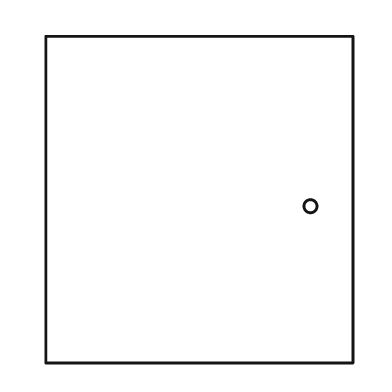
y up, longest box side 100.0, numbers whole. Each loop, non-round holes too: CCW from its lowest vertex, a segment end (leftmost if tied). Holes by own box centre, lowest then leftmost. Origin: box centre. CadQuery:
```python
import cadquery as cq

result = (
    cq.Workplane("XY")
    .moveTo(-47.0, -50.0)
    .lineTo(47.0, -50.0)
    .lineTo(47.0, 50.0)
    .lineTo(-47.0, 50.0)
    .close()
    .moveTo(34.0, -2.0)
    .circle(2.0)
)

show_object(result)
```